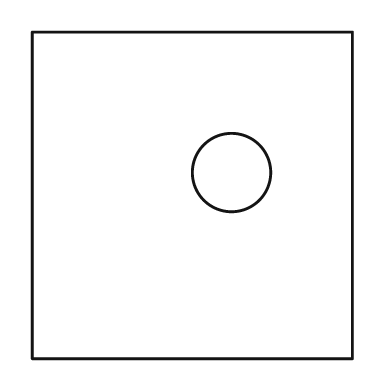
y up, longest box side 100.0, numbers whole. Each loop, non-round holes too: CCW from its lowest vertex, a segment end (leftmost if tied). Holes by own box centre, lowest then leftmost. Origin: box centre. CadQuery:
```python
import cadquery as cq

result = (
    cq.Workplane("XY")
    .moveTo(-49.0, -50.0)
    .lineTo(49.0, -50.0)
    .lineTo(49.0, 50.0)
    .lineTo(-49.0, 50.0)
    .close()
    .moveTo(12.0, 7.0)
    .circle(12.0)
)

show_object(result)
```